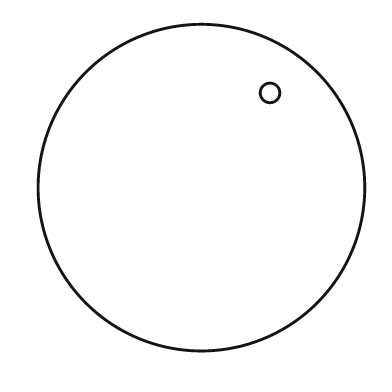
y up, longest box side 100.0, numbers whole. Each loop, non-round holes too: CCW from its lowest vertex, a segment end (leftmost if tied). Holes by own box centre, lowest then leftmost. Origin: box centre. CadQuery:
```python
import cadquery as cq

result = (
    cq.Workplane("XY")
    .moveTo(0.0, 0.0)
    .circle(50.0)
    .moveTo(21.0, 29.0)
    .circle(3.0)
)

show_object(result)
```